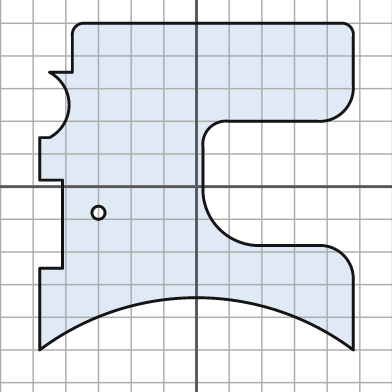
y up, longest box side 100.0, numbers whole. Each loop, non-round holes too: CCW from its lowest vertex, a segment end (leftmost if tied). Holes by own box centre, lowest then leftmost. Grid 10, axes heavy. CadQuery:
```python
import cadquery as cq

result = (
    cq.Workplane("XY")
    .moveTo(-48.0, -50.0)
    .threePointArc((0.0, -34.0), (48.0, -50.0))
    .lineTo(48.0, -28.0)
    .threePointArc((45.0, -21.0), (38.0, -18.0))
    .lineTo(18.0, -18.0)
    .threePointArc((7.0, -13.0), (2.0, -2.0))
    .lineTo(2.0, 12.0)
    .threePointArc((4.0, 18.0), (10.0, 20.0))
    .lineTo(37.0, 20.0)
    .threePointArc((45.0, 23.0), (48.0, 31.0))
    .lineTo(48.0, 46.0)
    .threePointArc((47.0, 49.0), (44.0, 50.0))
    .lineTo(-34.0, 50.0)
    .threePointArc((-37.0, 49.0), (-38.0, 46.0))
    .lineTo(-38.0, 35.0)
    .lineTo(-45.0, 35.0)
    .threePointArc((-39.0, 25.0), (-45.0, 15.0))
    .lineTo(-48.0, 15.0)
    .lineTo(-48.0, 2.0)
    .lineTo(-41.0, 2.0)
    .lineTo(-41.0, -25.0)
    .lineTo(-48.0, -25.0)
    .close()
    .moveTo(-30.0, -8.0)
    .circle(2.0)
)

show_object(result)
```